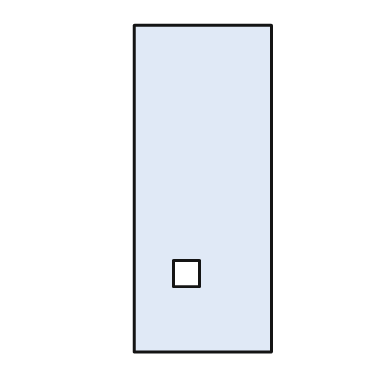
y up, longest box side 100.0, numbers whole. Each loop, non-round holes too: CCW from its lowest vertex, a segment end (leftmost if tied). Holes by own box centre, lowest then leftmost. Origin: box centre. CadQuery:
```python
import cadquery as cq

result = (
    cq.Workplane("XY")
    .moveTo(-21.0, -50.0)
    .lineTo(21.0, -50.0)
    .lineTo(21.0, 50.0)
    .lineTo(-21.0, 50.0)
    .close()
    .moveTo(-9.0, -30.0)
    .lineTo(-1.0, -30.0)
    .lineTo(-1.0, -22.0)
    .lineTo(-9.0, -22.0)
    .close()
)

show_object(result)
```